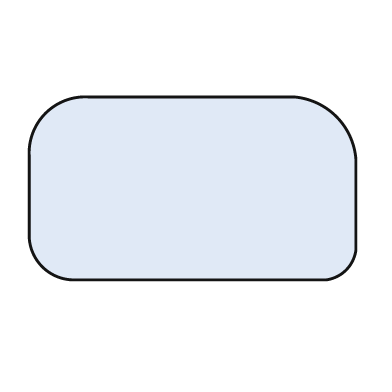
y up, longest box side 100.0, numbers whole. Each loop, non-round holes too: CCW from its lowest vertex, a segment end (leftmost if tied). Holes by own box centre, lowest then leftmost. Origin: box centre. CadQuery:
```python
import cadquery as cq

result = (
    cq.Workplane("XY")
    .moveTo(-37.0, -28.0)
    .lineTo(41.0, -28.0)
    .threePointArc((47.0, -25.0), (50.0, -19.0))
    .lineTo(50.0, 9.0)
    .threePointArc((44.0, 22.0), (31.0, 28.0))
    .lineTo(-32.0, 28.0)
    .threePointArc((-45.0, 23.0), (-50.0, 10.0))
    .lineTo(-50.0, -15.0)
    .threePointArc((-46.0, -24.0), (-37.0, -28.0))
    .close()
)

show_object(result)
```